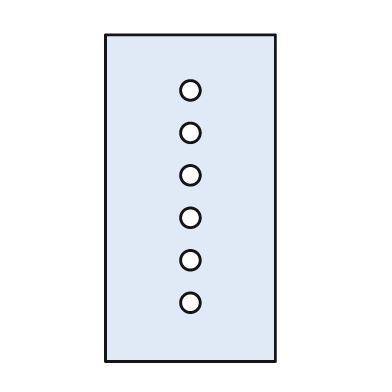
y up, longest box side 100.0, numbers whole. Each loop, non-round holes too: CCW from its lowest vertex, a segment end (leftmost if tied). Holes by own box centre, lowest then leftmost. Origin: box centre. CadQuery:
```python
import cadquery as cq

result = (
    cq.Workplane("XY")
    .moveTo(-26.0, -50.0)
    .lineTo(26.0, -50.0)
    .lineTo(26.0, 50.0)
    .lineTo(-26.0, 50.0)
    .close()
    .moveTo(0.0, -32.0)
    .circle(3.0)
    .moveTo(0.0, -19.0)
    .circle(3.0)
    .moveTo(0.0, -6.0)
    .circle(3.0)
    .moveTo(0.0, 7.0)
    .circle(3.0)
    .moveTo(0.0, 20.0)
    .circle(3.0)
    .moveTo(0.0, 33.0)
    .circle(3.0)
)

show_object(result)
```